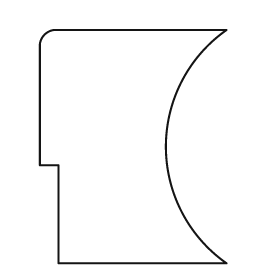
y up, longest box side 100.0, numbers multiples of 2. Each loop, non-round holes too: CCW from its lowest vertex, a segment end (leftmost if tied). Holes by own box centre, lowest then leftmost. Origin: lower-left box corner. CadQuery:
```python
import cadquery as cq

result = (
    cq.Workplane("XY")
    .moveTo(8.0, 0.0)
    .lineTo(80.0, 0.0)
    .threePointArc((54.0, 50.0), (80.0, 100.0))
    .lineTo(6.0, 100.0)
    .threePointArc((2.0, 98.0), (0.0, 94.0))
    .lineTo(0.0, 42.0)
    .lineTo(8.0, 42.0)
    .close()
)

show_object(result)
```